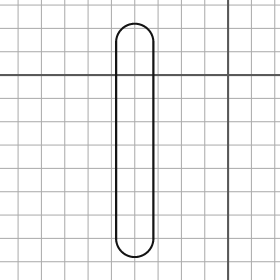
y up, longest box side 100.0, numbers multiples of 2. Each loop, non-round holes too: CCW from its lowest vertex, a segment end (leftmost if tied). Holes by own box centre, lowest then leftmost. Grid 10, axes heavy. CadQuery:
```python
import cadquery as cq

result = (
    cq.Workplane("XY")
    .moveTo(-48.0, -70.0)
    .threePointArc((-40.0, -78.0), (-32.0, -70.0))
    .lineTo(-32.0, 14.0)
    .threePointArc((-40.0, 22.0), (-48.0, 14.0))
    .close()
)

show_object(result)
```